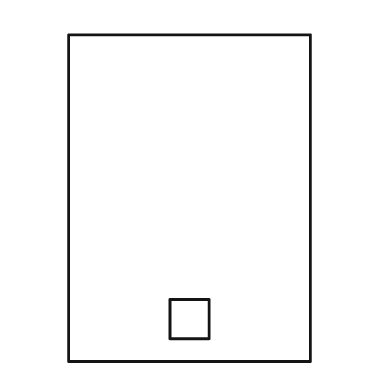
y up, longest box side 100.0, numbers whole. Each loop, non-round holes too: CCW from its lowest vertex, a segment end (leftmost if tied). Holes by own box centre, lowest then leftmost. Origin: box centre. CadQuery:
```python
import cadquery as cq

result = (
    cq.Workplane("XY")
    .moveTo(-37.0, -50.0)
    .lineTo(37.0, -50.0)
    .lineTo(37.0, 50.0)
    .lineTo(-37.0, 50.0)
    .close()
    .moveTo(-6.0, -43.0)
    .lineTo(6.0, -43.0)
    .lineTo(6.0, -31.0)
    .lineTo(-6.0, -31.0)
    .close()
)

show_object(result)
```